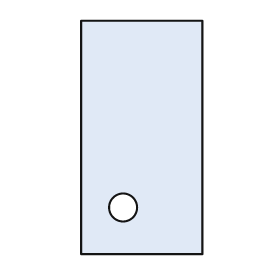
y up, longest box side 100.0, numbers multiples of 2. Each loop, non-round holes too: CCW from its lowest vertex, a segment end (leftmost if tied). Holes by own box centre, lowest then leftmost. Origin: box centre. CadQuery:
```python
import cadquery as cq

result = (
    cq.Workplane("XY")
    .moveTo(-26.0, -50.0)
    .lineTo(26.0, -50.0)
    .lineTo(26.0, 50.0)
    .lineTo(-26.0, 50.0)
    .close()
    .moveTo(-8.0, -30.0)
    .circle(6.0)
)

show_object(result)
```